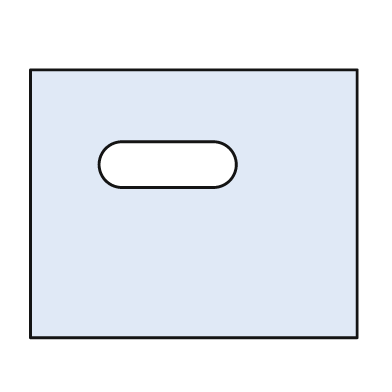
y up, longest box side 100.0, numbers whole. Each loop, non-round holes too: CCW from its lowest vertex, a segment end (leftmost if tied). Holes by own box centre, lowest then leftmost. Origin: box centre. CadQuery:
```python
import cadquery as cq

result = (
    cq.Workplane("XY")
    .moveTo(-50.0, -41.0)
    .lineTo(50.0, -41.0)
    .lineTo(50.0, 41.0)
    .lineTo(-50.0, 41.0)
    .close()
    .moveTo(-22.0, 5.0)
    .lineTo(6.0, 5.0)
    .threePointArc((13.0, 12.0), (6.0, 19.0))
    .lineTo(-22.0, 19.0)
    .threePointArc((-29.0, 12.0), (-22.0, 5.0))
    .close()
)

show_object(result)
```